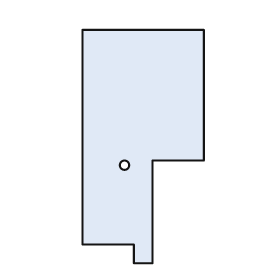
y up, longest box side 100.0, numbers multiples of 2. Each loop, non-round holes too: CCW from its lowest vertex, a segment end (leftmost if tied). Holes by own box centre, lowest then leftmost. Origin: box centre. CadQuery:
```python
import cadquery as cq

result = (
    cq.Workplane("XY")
    .moveTo(-4.0, -50.0)
    .lineTo(4.0, -50.0)
    .lineTo(4.0, -6.0)
    .lineTo(26.0, -6.0)
    .lineTo(26.0, 50.0)
    .lineTo(-26.0, 50.0)
    .lineTo(-26.0, -42.0)
    .lineTo(-4.0, -42.0)
    .close()
    .moveTo(-8.0, -8.0)
    .circle(2.0)
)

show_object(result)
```